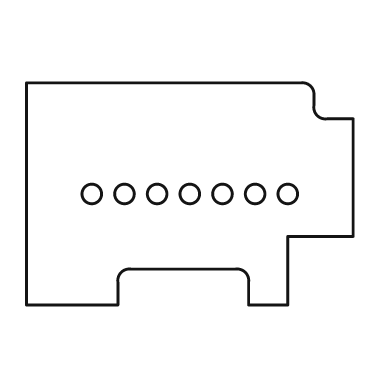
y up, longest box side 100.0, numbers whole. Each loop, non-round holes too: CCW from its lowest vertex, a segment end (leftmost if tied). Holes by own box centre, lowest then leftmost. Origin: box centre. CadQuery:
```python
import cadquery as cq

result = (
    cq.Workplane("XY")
    .moveTo(-50.0, -34.0)
    .lineTo(-22.0, -34.0)
    .lineTo(-22.0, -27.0)
    .threePointArc((-21.0, -24.0), (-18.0, -23.0))
    .lineTo(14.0, -23.0)
    .threePointArc((17.0, -24.0), (18.0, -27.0))
    .lineTo(18.0, -34.0)
    .lineTo(30.0, -34.0)
    .lineTo(30.0, -13.0)
    .lineTo(50.0, -13.0)
    .lineTo(50.0, 23.0)
    .lineTo(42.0, 23.0)
    .threePointArc((39.0, 24.0), (38.0, 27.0))
    .lineTo(38.0, 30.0)
    .threePointArc((37.0, 33.0), (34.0, 34.0))
    .lineTo(-50.0, 34.0)
    .close()
    .moveTo(-30.0, 0.0)
    .circle(3.0)
    .moveTo(-20.0, 0.0)
    .circle(3.0)
    .moveTo(-10.0, 0.0)
    .circle(3.0)
    .moveTo(0.0, 0.0)
    .circle(3.0)
    .moveTo(10.0, 0.0)
    .circle(3.0)
    .moveTo(20.0, 0.0)
    .circle(3.0)
    .moveTo(30.0, 0.0)
    .circle(3.0)
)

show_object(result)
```